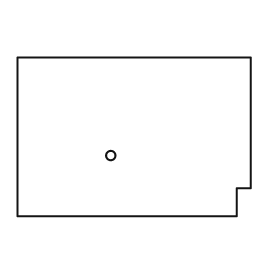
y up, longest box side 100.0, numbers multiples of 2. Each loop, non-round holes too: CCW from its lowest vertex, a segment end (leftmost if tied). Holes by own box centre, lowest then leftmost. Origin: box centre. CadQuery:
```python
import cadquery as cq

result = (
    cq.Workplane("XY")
    .moveTo(-50.0, -34.0)
    .lineTo(44.0, -34.0)
    .lineTo(44.0, -22.0)
    .lineTo(50.0, -22.0)
    .lineTo(50.0, 34.0)
    .lineTo(-50.0, 34.0)
    .close()
    .moveTo(-10.0, -8.0)
    .circle(2.0)
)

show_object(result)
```